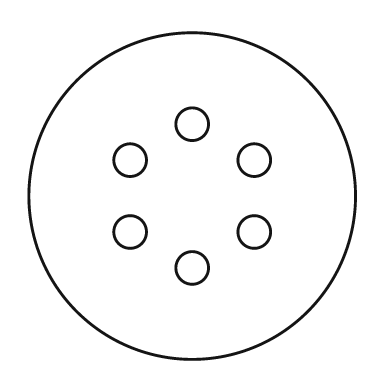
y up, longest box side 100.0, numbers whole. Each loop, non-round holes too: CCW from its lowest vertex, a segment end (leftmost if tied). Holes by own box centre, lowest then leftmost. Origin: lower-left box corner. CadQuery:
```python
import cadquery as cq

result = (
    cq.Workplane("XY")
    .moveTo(50.0, 50.0)
    .circle(50.0)
    .moveTo(50.0, 28.0)
    .circle(5.0)
    .moveTo(31.0, 39.0)
    .circle(5.0)
    .moveTo(69.0, 39.0)
    .circle(5.0)
    .moveTo(31.0, 61.0)
    .circle(5.0)
    .moveTo(69.0, 61.0)
    .circle(5.0)
    .moveTo(50.0, 72.0)
    .circle(5.0)
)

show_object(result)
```